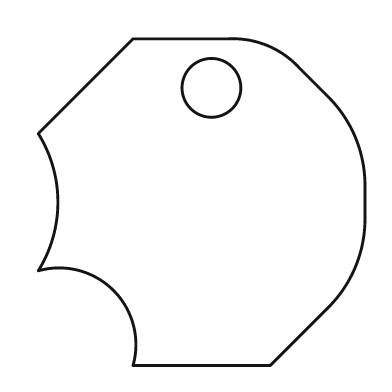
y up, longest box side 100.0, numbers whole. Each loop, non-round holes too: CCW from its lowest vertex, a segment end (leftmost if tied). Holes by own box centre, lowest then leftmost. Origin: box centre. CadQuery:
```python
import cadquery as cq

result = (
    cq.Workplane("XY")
    .moveTo(-21.0, -50.0)
    .lineTo(21.0, -50.0)
    .lineTo(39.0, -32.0)
    .threePointArc((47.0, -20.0), (50.0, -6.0))
    .lineTo(50.0, 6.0)
    .threePointArc((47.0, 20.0), (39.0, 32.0))
    .lineTo(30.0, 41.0)
    .threePointArc((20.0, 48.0), (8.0, 50.0))
    .lineTo(-21.0, 50.0)
    .lineTo(-50.0, 21.0)
    .threePointArc((-44.0, 0.0), (-50.0, -21.0))
    .threePointArc((-27.0, -27.0), (-21.0, -50.0))
    .close()
    .moveTo(3.0, 35.0)
    .circle(9.0)
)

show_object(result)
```